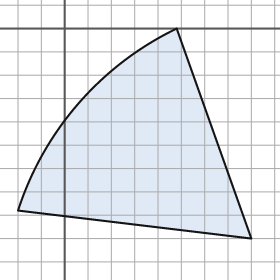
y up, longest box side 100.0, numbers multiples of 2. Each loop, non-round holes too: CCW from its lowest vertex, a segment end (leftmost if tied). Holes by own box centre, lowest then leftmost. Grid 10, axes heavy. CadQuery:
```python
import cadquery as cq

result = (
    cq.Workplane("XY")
    .moveTo(80.0, -90.0)
    .lineTo(48.0, 0.0)
    .threePointArc((6.0, -32.0), (-20.0, -78.0))
    .close()
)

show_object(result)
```